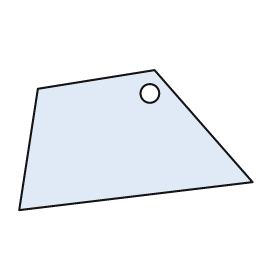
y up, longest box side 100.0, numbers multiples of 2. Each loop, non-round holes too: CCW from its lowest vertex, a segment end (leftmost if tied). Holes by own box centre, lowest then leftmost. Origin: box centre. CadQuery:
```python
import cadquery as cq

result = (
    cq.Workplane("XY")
    .moveTo(-50.0, -30.0)
    .lineTo(50.0, -18.0)
    .lineTo(8.0, 30.0)
    .lineTo(-42.0, 22.0)
    .close()
    .moveTo(6.0, 20.0)
    .circle(4.0)
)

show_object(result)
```